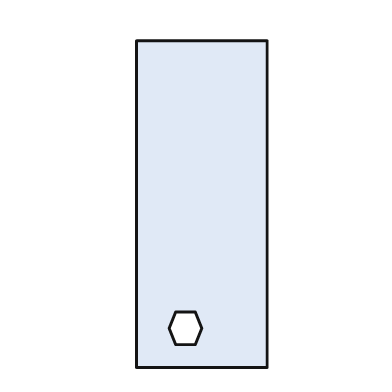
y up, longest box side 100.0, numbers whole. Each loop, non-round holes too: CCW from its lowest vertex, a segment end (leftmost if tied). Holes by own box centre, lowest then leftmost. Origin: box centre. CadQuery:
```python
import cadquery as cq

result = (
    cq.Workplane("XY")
    .moveTo(-20.0, -50.0)
    .lineTo(20.0, -50.0)
    .lineTo(20.0, 50.0)
    .lineTo(-20.0, 50.0)
    .close()
    .moveTo(-8.0, -43.0)
    .lineTo(-2.0, -43.0)
    .lineTo(0.0, -38.0)
    .lineTo(-2.0, -33.0)
    .lineTo(-8.0, -33.0)
    .lineTo(-10.0, -38.0)
    .close()
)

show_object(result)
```